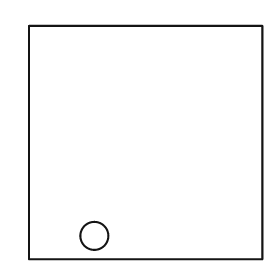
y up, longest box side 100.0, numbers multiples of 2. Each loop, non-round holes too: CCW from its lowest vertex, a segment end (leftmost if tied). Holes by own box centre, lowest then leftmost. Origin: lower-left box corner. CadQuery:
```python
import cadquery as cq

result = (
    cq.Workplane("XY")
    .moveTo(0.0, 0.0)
    .lineTo(100.0, 0.0)
    .lineTo(100.0, 100.0)
    .lineTo(0.0, 100.0)
    .close()
    .moveTo(28.0, 10.0)
    .circle(6.0)
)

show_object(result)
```